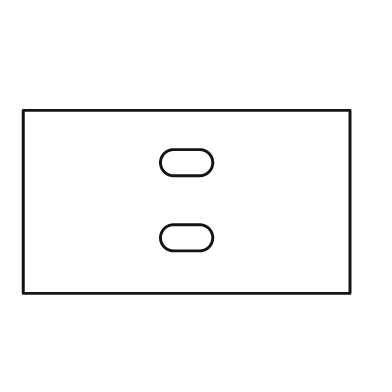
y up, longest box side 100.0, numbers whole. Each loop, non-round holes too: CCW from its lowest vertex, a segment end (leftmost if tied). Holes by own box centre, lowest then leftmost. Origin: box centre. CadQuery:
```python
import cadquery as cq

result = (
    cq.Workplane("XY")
    .moveTo(-50.0, -28.0)
    .lineTo(50.0, -28.0)
    .lineTo(50.0, 28.0)
    .lineTo(-50.0, 28.0)
    .close()
    .moveTo(-4.0, -15.0)
    .lineTo(4.0, -15.0)
    .threePointArc((8.0, -11.0), (4.0, -7.0))
    .lineTo(-4.0, -7.0)
    .threePointArc((-8.0, -11.0), (-4.0, -15.0))
    .close()
    .moveTo(-4.0, 8.0)
    .lineTo(4.0, 8.0)
    .threePointArc((8.0, 12.0), (4.0, 16.0))
    .lineTo(-4.0, 16.0)
    .threePointArc((-8.0, 12.0), (-4.0, 8.0))
    .close()
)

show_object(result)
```